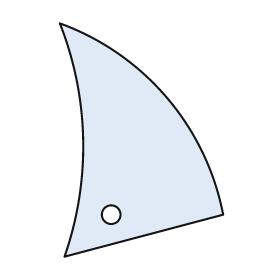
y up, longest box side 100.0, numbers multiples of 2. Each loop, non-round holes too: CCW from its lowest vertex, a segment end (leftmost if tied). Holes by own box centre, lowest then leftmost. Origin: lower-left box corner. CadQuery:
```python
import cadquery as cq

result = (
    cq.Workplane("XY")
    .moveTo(2.0, 0.0)
    .lineTo(70.0, 18.0)
    .threePointArc((46.0, 68.0), (0.0, 100.0))
    .threePointArc((10.0, 50.0), (2.0, 0.0))
    .close()
    .moveTo(22.0, 18.0)
    .circle(4.0)
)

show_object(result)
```